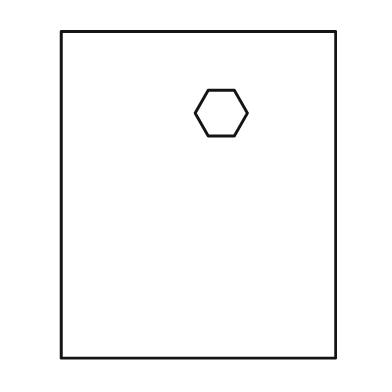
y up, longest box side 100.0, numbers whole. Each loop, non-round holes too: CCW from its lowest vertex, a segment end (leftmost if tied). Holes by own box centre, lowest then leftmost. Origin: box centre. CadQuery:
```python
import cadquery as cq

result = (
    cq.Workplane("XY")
    .moveTo(-42.0, -50.0)
    .lineTo(42.0, -50.0)
    .lineTo(42.0, 50.0)
    .lineTo(-42.0, 50.0)
    .close()
    .moveTo(3.0, 18.0)
    .lineTo(11.0, 18.0)
    .lineTo(15.0, 25.0)
    .lineTo(11.0, 32.0)
    .lineTo(3.0, 32.0)
    .lineTo(-1.0, 25.0)
    .close()
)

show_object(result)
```